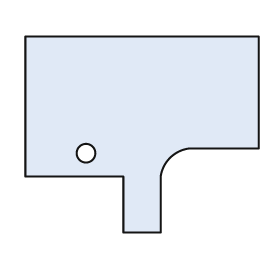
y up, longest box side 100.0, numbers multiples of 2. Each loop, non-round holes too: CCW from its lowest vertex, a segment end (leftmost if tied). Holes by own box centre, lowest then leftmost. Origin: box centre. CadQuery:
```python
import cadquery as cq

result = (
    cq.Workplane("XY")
    .moveTo(-8.0, -42.0)
    .lineTo(8.0, -42.0)
    .lineTo(8.0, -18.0)
    .threePointArc((12.0, -10.0), (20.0, -6.0))
    .lineTo(50.0, -6.0)
    .lineTo(50.0, 42.0)
    .lineTo(-50.0, 42.0)
    .lineTo(-50.0, -18.0)
    .lineTo(-8.0, -18.0)
    .close()
    .moveTo(-24.0, -8.0)
    .circle(4.0)
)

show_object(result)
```